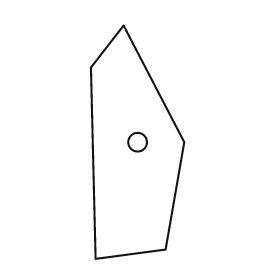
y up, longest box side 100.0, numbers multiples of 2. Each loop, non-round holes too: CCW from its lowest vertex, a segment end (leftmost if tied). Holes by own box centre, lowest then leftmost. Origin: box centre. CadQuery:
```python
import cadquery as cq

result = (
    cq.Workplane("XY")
    .moveTo(-18.0, -50.0)
    .lineTo(12.0, -46.0)
    .lineTo(20.0, 0.0)
    .lineTo(-6.0, 50.0)
    .lineTo(-20.0, 32.0)
    .close()
    .moveTo(0.0, 0.0)
    .circle(4.0)
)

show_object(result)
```